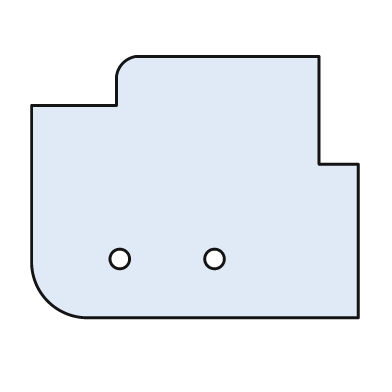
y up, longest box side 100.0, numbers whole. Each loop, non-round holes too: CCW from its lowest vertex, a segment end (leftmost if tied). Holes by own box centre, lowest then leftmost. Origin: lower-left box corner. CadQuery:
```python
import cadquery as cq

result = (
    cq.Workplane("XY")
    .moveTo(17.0, 0.0)
    .lineTo(100.0, 0.0)
    .lineTo(100.0, 47.0)
    .lineTo(88.0, 47.0)
    .lineTo(88.0, 80.0)
    .lineTo(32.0, 80.0)
    .threePointArc((28.0, 78.0), (26.0, 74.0))
    .lineTo(26.0, 65.0)
    .lineTo(0.0, 65.0)
    .lineTo(0.0, 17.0)
    .threePointArc((5.0, 5.0), (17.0, 0.0))
    .close()
    .moveTo(27.0, 18.0)
    .circle(3.0)
    .moveTo(56.0, 18.0)
    .circle(3.0)
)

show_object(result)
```